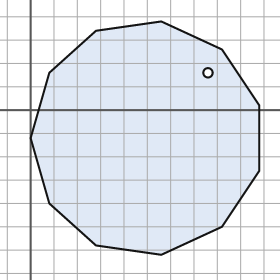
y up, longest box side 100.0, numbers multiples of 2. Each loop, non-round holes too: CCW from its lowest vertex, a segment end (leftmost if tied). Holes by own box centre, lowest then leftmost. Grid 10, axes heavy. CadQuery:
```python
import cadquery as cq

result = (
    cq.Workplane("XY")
    .moveTo(56.0, -62.0)
    .lineTo(82.0, -50.0)
    .lineTo(98.0, -26.0)
    .lineTo(98.0, 2.0)
    .lineTo(82.0, 26.0)
    .lineTo(56.0, 38.0)
    .lineTo(28.0, 34.0)
    .lineTo(8.0, 16.0)
    .lineTo(0.0, -12.0)
    .lineTo(8.0, -40.0)
    .lineTo(28.0, -58.0)
    .close()
    .moveTo(76.0, 16.0)
    .circle(2.0)
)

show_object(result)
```